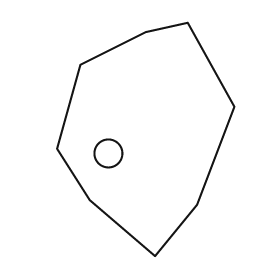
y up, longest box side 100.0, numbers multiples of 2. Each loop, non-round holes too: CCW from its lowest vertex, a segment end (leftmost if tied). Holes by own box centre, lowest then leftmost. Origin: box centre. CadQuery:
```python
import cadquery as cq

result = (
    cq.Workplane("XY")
    .moveTo(4.0, -50.0)
    .lineTo(22.0, -28.0)
    .lineTo(38.0, 14.0)
    .lineTo(18.0, 50.0)
    .lineTo(0.0, 46.0)
    .lineTo(-28.0, 32.0)
    .lineTo(-38.0, -4.0)
    .lineTo(-24.0, -26.0)
    .close()
    .moveTo(-16.0, -6.0)
    .circle(6.0)
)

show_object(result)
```